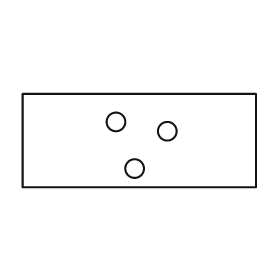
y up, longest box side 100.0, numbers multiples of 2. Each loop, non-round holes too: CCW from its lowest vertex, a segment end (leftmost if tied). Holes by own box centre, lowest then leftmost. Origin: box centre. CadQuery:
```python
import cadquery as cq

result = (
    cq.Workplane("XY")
    .moveTo(-50.0, -20.0)
    .lineTo(50.0, -20.0)
    .lineTo(50.0, 20.0)
    .lineTo(-50.0, 20.0)
    .close()
    .moveTo(-2.0, -12.0)
    .circle(4.0)
    .moveTo(12.0, 4.0)
    .circle(4.0)
    .moveTo(-10.0, 8.0)
    .circle(4.0)
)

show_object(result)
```